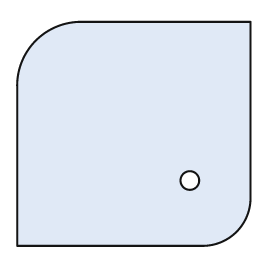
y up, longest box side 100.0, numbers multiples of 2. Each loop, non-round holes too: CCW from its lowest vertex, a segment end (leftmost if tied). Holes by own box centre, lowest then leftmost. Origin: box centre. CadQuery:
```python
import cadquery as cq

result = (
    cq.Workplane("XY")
    .moveTo(-50.0, -48.0)
    .lineTo(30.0, -48.0)
    .threePointArc((44.0, -42.0), (50.0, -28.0))
    .lineTo(50.0, 48.0)
    .lineTo(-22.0, 48.0)
    .threePointArc((-42.0, 40.0), (-50.0, 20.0))
    .close()
    .moveTo(24.0, -20.0)
    .circle(4.0)
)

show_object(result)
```